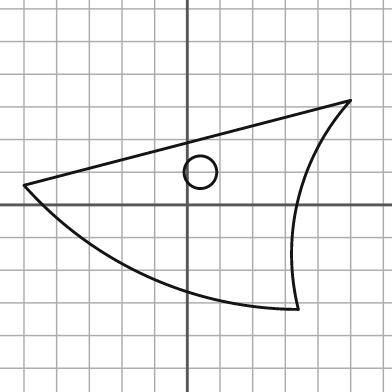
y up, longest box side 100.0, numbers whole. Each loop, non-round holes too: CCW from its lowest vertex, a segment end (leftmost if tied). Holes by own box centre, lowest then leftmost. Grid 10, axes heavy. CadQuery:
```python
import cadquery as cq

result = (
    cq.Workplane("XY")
    .moveTo(34.0, -32.0)
    .threePointArc((34.0, 2.0), (50.0, 32.0))
    .lineTo(-50.0, 6.0)
    .threePointArc((-12.0, -22.0), (34.0, -32.0))
    .close()
    .moveTo(4.0, 10.0)
    .circle(5.0)
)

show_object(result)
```